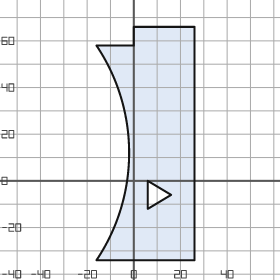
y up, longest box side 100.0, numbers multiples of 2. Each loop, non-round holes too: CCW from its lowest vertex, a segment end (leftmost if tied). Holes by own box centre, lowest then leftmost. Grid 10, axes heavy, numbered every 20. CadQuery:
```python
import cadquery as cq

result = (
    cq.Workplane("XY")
    .moveTo(-16.0, -34.0)
    .lineTo(26.0, -34.0)
    .lineTo(26.0, 66.0)
    .lineTo(0.0, 66.0)
    .lineTo(0.0, 58.0)
    .lineTo(-16.0, 58.0)
    .threePointArc((-2.0, 12.0), (-16.0, -34.0))
    .close()
    .moveTo(6.0, -12.0)
    .lineTo(16.0, -6.0)
    .lineTo(6.0, 0.0)
    .close()
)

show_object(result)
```